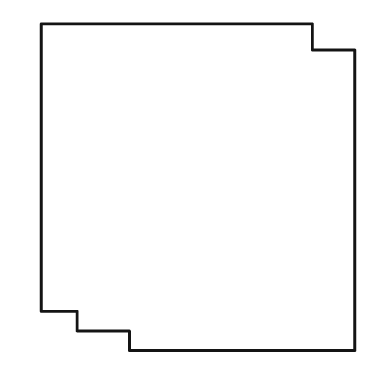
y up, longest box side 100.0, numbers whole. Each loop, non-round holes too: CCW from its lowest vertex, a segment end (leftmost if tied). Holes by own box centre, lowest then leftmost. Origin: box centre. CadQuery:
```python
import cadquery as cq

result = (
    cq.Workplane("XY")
    .moveTo(-21.0, -50.0)
    .lineTo(48.0, -50.0)
    .lineTo(48.0, 42.0)
    .lineTo(35.0, 42.0)
    .lineTo(35.0, 50.0)
    .lineTo(-48.0, 50.0)
    .lineTo(-48.0, -38.0)
    .lineTo(-37.0, -38.0)
    .lineTo(-37.0, -44.0)
    .lineTo(-21.0, -44.0)
    .close()
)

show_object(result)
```